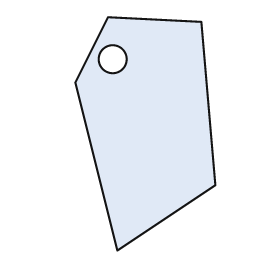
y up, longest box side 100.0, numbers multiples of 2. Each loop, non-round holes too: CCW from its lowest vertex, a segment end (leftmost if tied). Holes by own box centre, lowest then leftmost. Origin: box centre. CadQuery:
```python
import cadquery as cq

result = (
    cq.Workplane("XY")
    .moveTo(-12.0, -50.0)
    .lineTo(30.0, -22.0)
    .lineTo(24.0, 48.0)
    .lineTo(-16.0, 50.0)
    .lineTo(-30.0, 22.0)
    .close()
    .moveTo(-14.0, 32.0)
    .circle(6.0)
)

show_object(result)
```